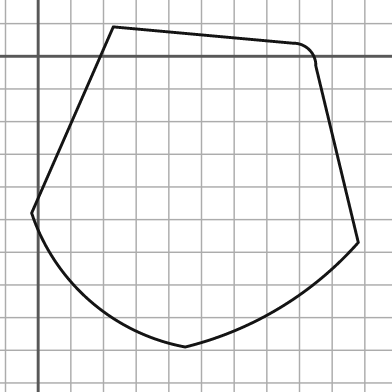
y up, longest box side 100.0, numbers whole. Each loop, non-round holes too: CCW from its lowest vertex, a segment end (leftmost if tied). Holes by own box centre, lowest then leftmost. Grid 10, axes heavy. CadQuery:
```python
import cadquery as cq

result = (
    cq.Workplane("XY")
    .moveTo(45.0, -89.0)
    .threePointArc((74.0, -77.0), (98.0, -57.0))
    .lineTo(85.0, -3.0)
    .threePointArc((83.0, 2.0), (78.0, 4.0))
    .lineTo(23.0, 9.0)
    .lineTo(-2.0, -48.0)
    .threePointArc((16.0, -75.0), (45.0, -89.0))
    .close()
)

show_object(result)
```